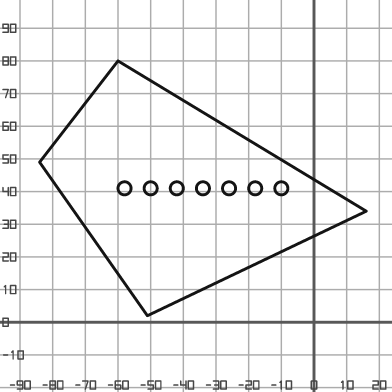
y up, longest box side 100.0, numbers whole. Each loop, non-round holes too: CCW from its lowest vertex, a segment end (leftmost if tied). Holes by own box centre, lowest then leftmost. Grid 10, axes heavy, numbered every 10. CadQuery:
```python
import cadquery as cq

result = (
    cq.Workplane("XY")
    .moveTo(-51.0, 2.0)
    .lineTo(16.0, 34.0)
    .lineTo(-60.0, 80.0)
    .lineTo(-84.0, 49.0)
    .close()
    .moveTo(-58.0, 41.0)
    .circle(2.0)
    .moveTo(-50.0, 41.0)
    .circle(2.0)
    .moveTo(-42.0, 41.0)
    .circle(2.0)
    .moveTo(-34.0, 41.0)
    .circle(2.0)
    .moveTo(-26.0, 41.0)
    .circle(2.0)
    .moveTo(-18.0, 41.0)
    .circle(2.0)
    .moveTo(-10.0, 41.0)
    .circle(2.0)
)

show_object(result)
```